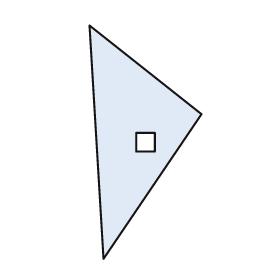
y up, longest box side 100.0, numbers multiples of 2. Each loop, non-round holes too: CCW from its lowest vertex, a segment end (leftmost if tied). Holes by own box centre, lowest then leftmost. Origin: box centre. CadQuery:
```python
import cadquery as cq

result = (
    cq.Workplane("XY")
    .moveTo(-18.0, -50.0)
    .lineTo(24.0, 12.0)
    .lineTo(-24.0, 50.0)
    .close()
    .moveTo(-4.0, -4.0)
    .lineTo(4.0, -4.0)
    .lineTo(4.0, 4.0)
    .lineTo(-4.0, 4.0)
    .close()
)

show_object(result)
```